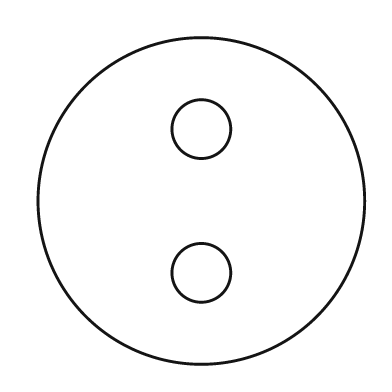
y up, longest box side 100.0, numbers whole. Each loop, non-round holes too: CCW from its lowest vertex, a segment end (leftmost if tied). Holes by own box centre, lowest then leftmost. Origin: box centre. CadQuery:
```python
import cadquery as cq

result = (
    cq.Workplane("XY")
    .moveTo(0.0, 0.0)
    .circle(50.0)
    .moveTo(0.0, -22.0)
    .circle(9.0)
    .moveTo(0.0, 22.0)
    .circle(9.0)
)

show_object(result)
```